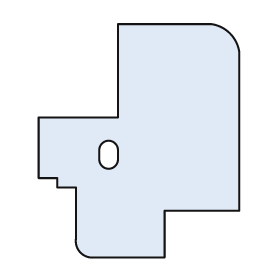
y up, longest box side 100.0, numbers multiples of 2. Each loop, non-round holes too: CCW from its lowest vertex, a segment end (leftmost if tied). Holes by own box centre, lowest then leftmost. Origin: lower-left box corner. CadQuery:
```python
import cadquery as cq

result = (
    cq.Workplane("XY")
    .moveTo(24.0, 0.0)
    .lineTo(54.0, 0.0)
    .lineTo(54.0, 20.0)
    .lineTo(86.0, 20.0)
    .lineTo(86.0, 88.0)
    .threePointArc((82.0, 96.0), (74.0, 100.0))
    .lineTo(34.0, 100.0)
    .lineTo(34.0, 60.0)
    .lineTo(0.0, 60.0)
    .lineTo(0.0, 34.0)
    .lineTo(8.0, 34.0)
    .lineTo(8.0, 30.0)
    .lineTo(16.0, 30.0)
    .lineTo(16.0, 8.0)
    .threePointArc((18.0, 2.0), (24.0, 0.0))
    .close()
    .moveTo(26.0, 42.0)
    .threePointArc((30.0, 38.0), (34.0, 42.0))
    .lineTo(34.0, 46.0)
    .threePointArc((30.0, 50.0), (26.0, 46.0))
    .close()
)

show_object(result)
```